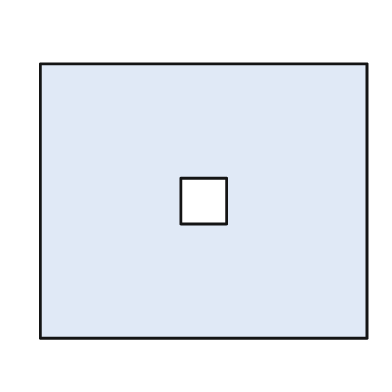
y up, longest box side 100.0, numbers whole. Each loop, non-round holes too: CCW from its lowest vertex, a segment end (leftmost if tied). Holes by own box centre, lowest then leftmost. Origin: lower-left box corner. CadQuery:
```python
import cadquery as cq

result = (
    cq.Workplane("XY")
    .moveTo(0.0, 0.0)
    .lineTo(100.0, 0.0)
    .lineTo(100.0, 84.0)
    .lineTo(0.0, 84.0)
    .close()
    .moveTo(43.0, 35.0)
    .lineTo(57.0, 35.0)
    .lineTo(57.0, 49.0)
    .lineTo(43.0, 49.0)
    .close()
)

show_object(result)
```